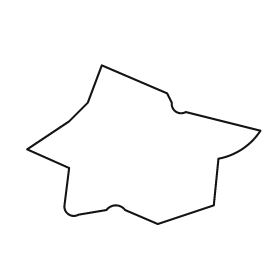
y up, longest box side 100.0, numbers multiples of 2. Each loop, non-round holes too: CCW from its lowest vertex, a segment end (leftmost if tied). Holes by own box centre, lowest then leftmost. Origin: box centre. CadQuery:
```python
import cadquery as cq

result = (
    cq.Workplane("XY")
    .moveTo(6.0, -34.0)
    .lineTo(30.0, -26.0)
    .lineTo(32.0, -6.0)
    .threePointArc((42.0, -2.0), (50.0, 6.0))
    .lineTo(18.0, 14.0)
    .threePointArc((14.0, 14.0), (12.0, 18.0))
    .lineTo(10.0, 22.0)
    .lineTo(-18.0, 34.0)
    .lineTo(-24.0, 18.0)
    .lineTo(-32.0, 10.0)
    .lineTo(-50.0, -2.0)
    .lineTo(-32.0, -10.0)
    .lineTo(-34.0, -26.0)
    .threePointArc((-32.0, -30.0), (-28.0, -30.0))
    .lineTo(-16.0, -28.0)
    .threePointArc((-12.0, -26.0), (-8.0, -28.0))
    .close()
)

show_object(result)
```